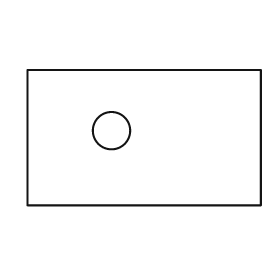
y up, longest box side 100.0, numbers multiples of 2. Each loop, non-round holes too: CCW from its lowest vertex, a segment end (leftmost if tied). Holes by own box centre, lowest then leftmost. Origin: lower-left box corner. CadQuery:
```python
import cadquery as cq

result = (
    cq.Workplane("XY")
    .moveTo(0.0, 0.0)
    .lineTo(100.0, 0.0)
    .lineTo(100.0, 58.0)
    .lineTo(0.0, 58.0)
    .close()
    .moveTo(36.0, 32.0)
    .circle(8.0)
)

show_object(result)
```